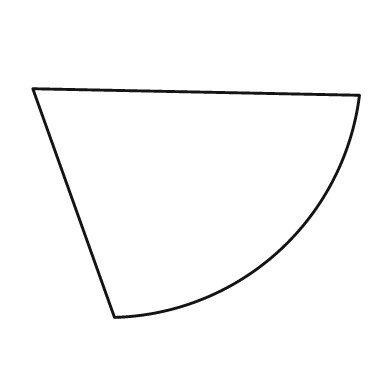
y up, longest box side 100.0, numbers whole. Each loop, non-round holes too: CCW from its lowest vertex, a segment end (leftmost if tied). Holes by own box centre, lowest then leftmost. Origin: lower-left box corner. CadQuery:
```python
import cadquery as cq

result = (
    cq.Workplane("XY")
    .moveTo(25.0, 0.0)
    .threePointArc((75.0, 20.0), (100.0, 68.0))
    .lineTo(0.0, 70.0)
    .close()
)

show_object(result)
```